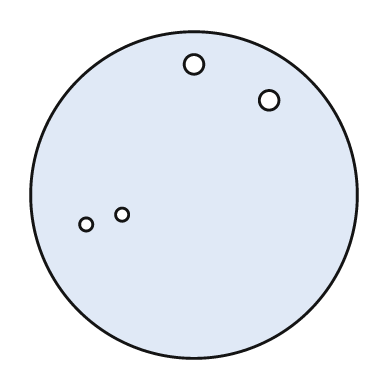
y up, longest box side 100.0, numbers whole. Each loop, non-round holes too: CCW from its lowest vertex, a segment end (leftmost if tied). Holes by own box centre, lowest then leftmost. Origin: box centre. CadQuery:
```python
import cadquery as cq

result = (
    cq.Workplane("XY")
    .moveTo(0.0, 0.0)
    .circle(50.0)
    .moveTo(-33.0, -9.0)
    .circle(2.0)
    .moveTo(-22.0, -6.0)
    .circle(2.0)
    .moveTo(23.0, 29.0)
    .circle(3.0)
    .moveTo(0.0, 40.0)
    .circle(3.0)
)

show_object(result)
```